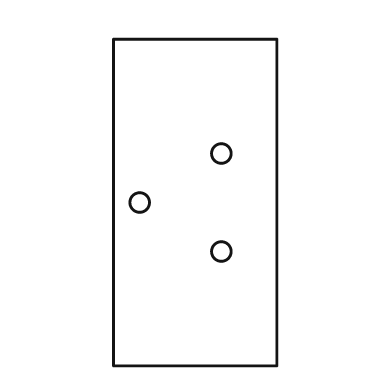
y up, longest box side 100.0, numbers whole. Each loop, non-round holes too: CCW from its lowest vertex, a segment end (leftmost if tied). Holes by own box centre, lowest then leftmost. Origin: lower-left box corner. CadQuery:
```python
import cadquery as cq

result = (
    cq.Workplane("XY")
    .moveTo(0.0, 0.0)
    .lineTo(50.0, 0.0)
    .lineTo(50.0, 100.0)
    .lineTo(0.0, 100.0)
    .close()
    .moveTo(33.0, 35.0)
    .circle(3.0)
    .moveTo(8.0, 50.0)
    .circle(3.0)
    .moveTo(33.0, 65.0)
    .circle(3.0)
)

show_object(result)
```